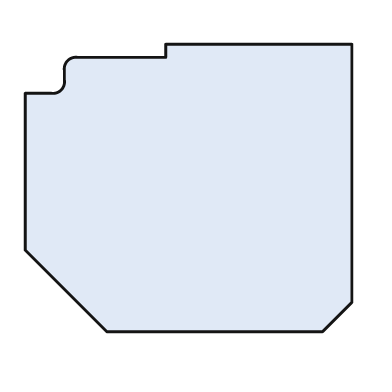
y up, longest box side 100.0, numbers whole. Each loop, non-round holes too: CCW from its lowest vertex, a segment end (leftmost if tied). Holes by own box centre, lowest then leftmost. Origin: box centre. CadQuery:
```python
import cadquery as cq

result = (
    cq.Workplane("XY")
    .moveTo(-25.0, -44.0)
    .lineTo(41.0, -44.0)
    .lineTo(50.0, -35.0)
    .lineTo(50.0, 44.0)
    .lineTo(-7.0, 44.0)
    .lineTo(-7.0, 40.0)
    .lineTo(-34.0, 40.0)
    .threePointArc((-37.0, 39.0), (-38.0, 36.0))
    .lineTo(-38.0, 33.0)
    .threePointArc((-39.0, 30.0), (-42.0, 29.0))
    .lineTo(-50.0, 29.0)
    .lineTo(-50.0, -19.0)
    .close()
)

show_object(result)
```